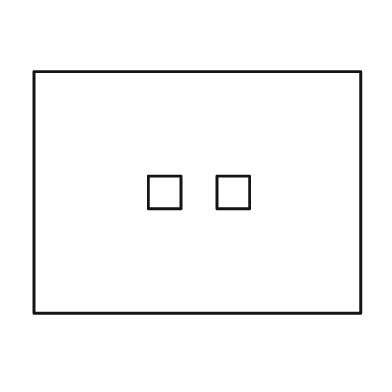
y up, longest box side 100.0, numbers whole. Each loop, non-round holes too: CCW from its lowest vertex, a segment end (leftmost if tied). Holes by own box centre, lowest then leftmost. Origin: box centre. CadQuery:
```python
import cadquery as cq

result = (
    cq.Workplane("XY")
    .moveTo(-50.0, -37.0)
    .lineTo(50.0, -37.0)
    .lineTo(50.0, 37.0)
    .lineTo(-50.0, 37.0)
    .close()
    .moveTo(-15.0, -5.0)
    .lineTo(-5.0, -5.0)
    .lineTo(-5.0, 5.0)
    .lineTo(-15.0, 5.0)
    .close()
    .moveTo(6.0, -5.0)
    .lineTo(16.0, -5.0)
    .lineTo(16.0, 5.0)
    .lineTo(6.0, 5.0)
    .close()
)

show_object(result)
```